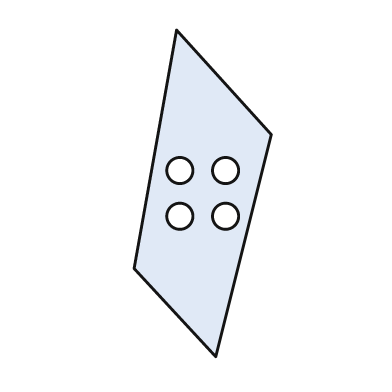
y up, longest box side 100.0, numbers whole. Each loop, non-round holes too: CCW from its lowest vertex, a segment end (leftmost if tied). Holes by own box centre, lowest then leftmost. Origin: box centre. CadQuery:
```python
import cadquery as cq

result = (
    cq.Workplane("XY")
    .moveTo(4.0, -50.0)
    .lineTo(21.0, 18.0)
    .lineTo(-8.0, 50.0)
    .lineTo(-21.0, -23.0)
    .close()
    .moveTo(-7.0, -7.0)
    .circle(4.0)
    .moveTo(7.0, -7.0)
    .circle(4.0)
    .moveTo(-7.0, 7.0)
    .circle(4.0)
    .moveTo(7.0, 7.0)
    .circle(4.0)
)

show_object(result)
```